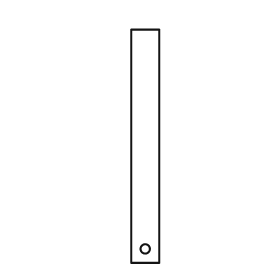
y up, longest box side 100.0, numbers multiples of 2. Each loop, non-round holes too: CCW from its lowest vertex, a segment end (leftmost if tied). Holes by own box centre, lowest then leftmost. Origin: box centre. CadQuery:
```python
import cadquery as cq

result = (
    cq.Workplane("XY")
    .moveTo(-6.0, -50.0)
    .lineTo(6.0, -50.0)
    .lineTo(6.0, 50.0)
    .lineTo(-6.0, 50.0)
    .close()
    .moveTo(0.0, -44.0)
    .circle(2.0)
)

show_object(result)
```